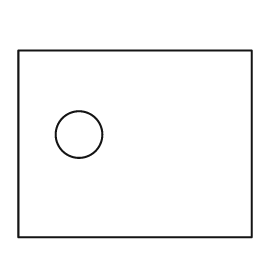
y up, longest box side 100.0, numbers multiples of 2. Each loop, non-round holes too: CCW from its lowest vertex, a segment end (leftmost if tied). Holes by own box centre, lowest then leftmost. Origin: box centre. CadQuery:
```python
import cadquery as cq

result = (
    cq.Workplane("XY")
    .moveTo(-50.0, -40.0)
    .lineTo(50.0, -40.0)
    .lineTo(50.0, 40.0)
    .lineTo(-50.0, 40.0)
    .close()
    .moveTo(-24.0, 4.0)
    .circle(10.0)
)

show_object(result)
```